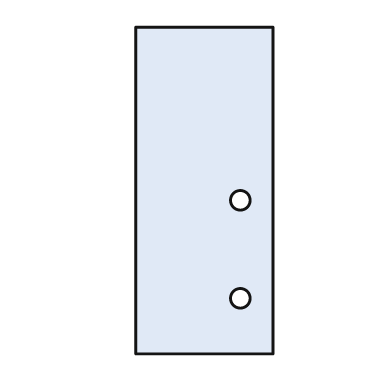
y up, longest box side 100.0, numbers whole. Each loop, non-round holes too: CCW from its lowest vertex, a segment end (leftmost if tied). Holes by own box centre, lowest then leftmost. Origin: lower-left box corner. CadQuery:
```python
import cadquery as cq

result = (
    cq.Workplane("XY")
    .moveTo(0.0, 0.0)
    .lineTo(42.0, 0.0)
    .lineTo(42.0, 100.0)
    .lineTo(0.0, 100.0)
    .close()
    .moveTo(32.0, 17.0)
    .circle(3.0)
    .moveTo(32.0, 47.0)
    .circle(3.0)
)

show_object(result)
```